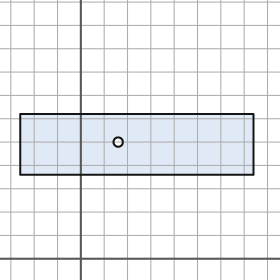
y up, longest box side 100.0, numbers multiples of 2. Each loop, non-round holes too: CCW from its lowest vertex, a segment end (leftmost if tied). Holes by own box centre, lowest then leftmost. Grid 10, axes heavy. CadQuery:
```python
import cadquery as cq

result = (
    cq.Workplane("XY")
    .moveTo(-26.0, 36.0)
    .lineTo(74.0, 36.0)
    .lineTo(74.0, 62.0)
    .lineTo(-26.0, 62.0)
    .close()
    .moveTo(16.0, 50.0)
    .circle(2.0)
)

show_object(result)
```